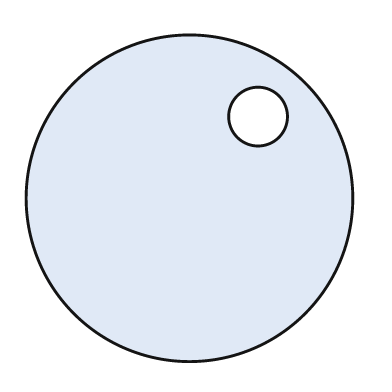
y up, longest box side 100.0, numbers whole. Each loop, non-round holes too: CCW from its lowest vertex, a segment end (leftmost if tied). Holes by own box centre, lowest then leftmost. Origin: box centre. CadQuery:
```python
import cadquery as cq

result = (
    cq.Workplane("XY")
    .moveTo(0.0, 0.0)
    .circle(50.0)
    .moveTo(21.0, 25.0)
    .circle(9.0)
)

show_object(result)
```